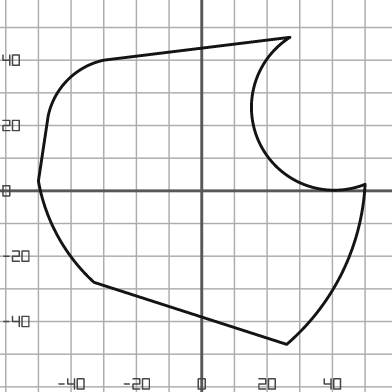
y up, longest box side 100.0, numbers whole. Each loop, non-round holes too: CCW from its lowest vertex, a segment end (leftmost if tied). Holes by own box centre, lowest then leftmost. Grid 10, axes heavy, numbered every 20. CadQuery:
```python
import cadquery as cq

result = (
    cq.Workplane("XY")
    .moveTo(26.0, -47.0)
    .threePointArc((43.0, -25.0), (50.0, 2.0))
    .threePointArc((18.0, 14.0), (27.0, 47.0))
    .lineTo(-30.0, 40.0)
    .threePointArc((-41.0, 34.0), (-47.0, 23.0))
    .lineTo(-50.0, 3.0)
    .threePointArc((-44.0, -14.0), (-33.0, -28.0))
    .close()
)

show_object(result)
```